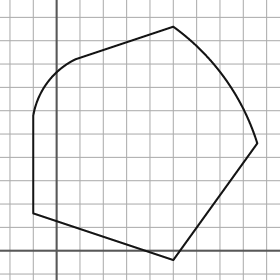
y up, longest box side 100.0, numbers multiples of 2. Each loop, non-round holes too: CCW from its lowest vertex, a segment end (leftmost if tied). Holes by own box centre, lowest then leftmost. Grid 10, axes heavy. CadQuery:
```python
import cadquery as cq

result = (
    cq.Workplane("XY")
    .moveTo(50.0, -4.0)
    .lineTo(86.0, 46.0)
    .threePointArc((72.0, 74.0), (50.0, 96.0))
    .lineTo(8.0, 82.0)
    .threePointArc((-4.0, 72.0), (-10.0, 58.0))
    .lineTo(-10.0, 16.0)
    .close()
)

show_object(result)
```